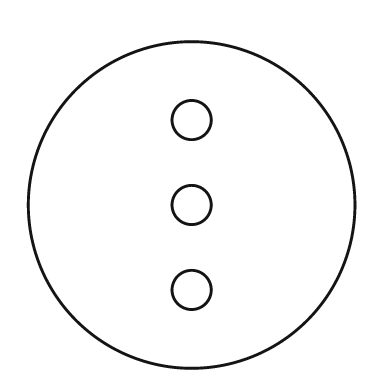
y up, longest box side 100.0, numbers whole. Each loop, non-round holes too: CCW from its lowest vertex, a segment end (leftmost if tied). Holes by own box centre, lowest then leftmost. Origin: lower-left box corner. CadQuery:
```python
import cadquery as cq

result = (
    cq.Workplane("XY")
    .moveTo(50.0, 50.0)
    .circle(50.0)
    .moveTo(50.0, 24.0)
    .circle(6.0)
    .moveTo(50.0, 50.0)
    .circle(6.0)
    .moveTo(50.0, 76.0)
    .circle(6.0)
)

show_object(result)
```